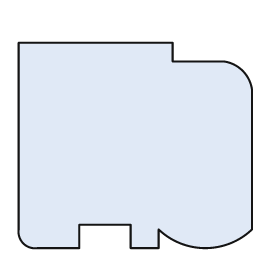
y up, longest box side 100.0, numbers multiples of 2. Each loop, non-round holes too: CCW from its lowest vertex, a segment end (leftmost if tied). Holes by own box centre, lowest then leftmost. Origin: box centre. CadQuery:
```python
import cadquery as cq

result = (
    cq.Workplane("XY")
    .moveTo(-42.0, -44.0)
    .lineTo(-24.0, -44.0)
    .lineTo(-24.0, -34.0)
    .lineTo(-2.0, -34.0)
    .lineTo(-2.0, -44.0)
    .lineTo(10.0, -44.0)
    .lineTo(10.0, -36.0)
    .threePointArc((30.0, -44.0), (50.0, -36.0))
    .lineTo(50.0, 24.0)
    .threePointArc((46.0, 32.0), (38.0, 36.0))
    .lineTo(16.0, 36.0)
    .lineTo(16.0, 44.0)
    .lineTo(-50.0, 44.0)
    .lineTo(-50.0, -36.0)
    .threePointArc((-48.0, -42.0), (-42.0, -44.0))
    .close()
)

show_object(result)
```